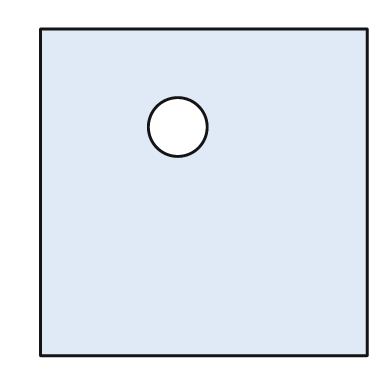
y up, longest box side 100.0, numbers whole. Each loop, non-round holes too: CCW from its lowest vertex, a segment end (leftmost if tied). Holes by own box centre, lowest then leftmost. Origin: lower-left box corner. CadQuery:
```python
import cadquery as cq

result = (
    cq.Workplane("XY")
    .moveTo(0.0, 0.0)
    .lineTo(100.0, 0.0)
    .lineTo(100.0, 100.0)
    .lineTo(0.0, 100.0)
    .close()
    .moveTo(42.0, 70.0)
    .circle(9.0)
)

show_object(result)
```